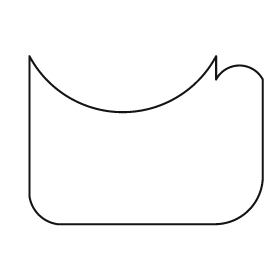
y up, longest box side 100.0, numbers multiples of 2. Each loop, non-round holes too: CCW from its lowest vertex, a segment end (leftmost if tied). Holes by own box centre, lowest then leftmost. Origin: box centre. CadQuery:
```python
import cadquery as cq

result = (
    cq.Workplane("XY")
    .moveTo(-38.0, -36.0)
    .lineTo(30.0, -36.0)
    .threePointArc((44.0, -30.0), (50.0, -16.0))
    .lineTo(50.0, 26.0)
    .threePointArc((40.0, 32.0), (30.0, 26.0))
    .lineTo(30.0, 36.0)
    .threePointArc((-10.0, 12.0), (-50.0, 36.0))
    .lineTo(-50.0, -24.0)
    .threePointArc((-46.0, -32.0), (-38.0, -36.0))
    .close()
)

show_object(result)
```